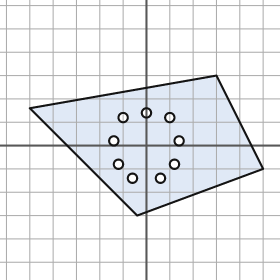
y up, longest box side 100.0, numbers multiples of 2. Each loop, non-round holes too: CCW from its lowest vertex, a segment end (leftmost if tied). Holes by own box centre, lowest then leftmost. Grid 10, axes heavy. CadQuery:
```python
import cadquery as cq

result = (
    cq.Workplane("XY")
    .moveTo(-4.0, -30.0)
    .lineTo(50.0, -10.0)
    .lineTo(30.0, 30.0)
    .lineTo(-50.0, 16.0)
    .close()
    .moveTo(-6.0, -14.0)
    .circle(2.0)
    .moveTo(6.0, -14.0)
    .circle(2.0)
    .moveTo(-12.0, -8.0)
    .circle(2.0)
    .moveTo(12.0, -8.0)
    .circle(2.0)
    .moveTo(-14.0, 2.0)
    .circle(2.0)
    .moveTo(14.0, 2.0)
    .circle(2.0)
    .moveTo(-10.0, 12.0)
    .circle(2.0)
    .moveTo(10.0, 12.0)
    .circle(2.0)
    .moveTo(0.0, 14.0)
    .circle(2.0)
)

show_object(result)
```